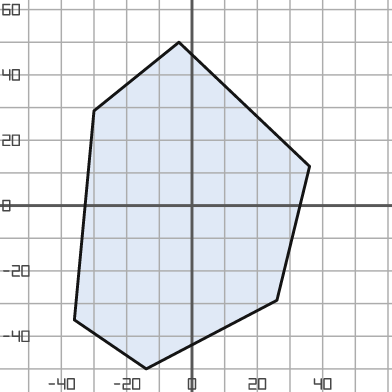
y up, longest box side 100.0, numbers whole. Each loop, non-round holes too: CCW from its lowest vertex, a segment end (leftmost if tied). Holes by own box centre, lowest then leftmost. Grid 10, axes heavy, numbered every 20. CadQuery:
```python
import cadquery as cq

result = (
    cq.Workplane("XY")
    .moveTo(-14.0, -50.0)
    .lineTo(26.0, -29.0)
    .lineTo(36.0, 12.0)
    .lineTo(-4.0, 50.0)
    .lineTo(-30.0, 29.0)
    .lineTo(-36.0, -35.0)
    .close()
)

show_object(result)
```